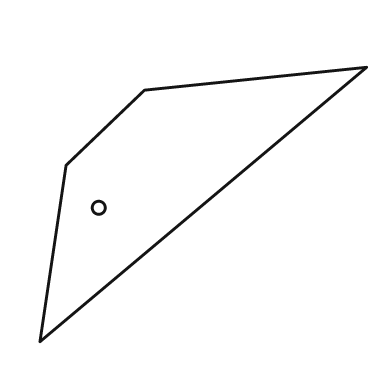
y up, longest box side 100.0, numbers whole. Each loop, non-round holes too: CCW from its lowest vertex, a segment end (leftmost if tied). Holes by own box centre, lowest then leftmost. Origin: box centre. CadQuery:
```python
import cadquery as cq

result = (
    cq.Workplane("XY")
    .moveTo(-50.0, -42.0)
    .lineTo(50.0, 42.0)
    .lineTo(-18.0, 35.0)
    .lineTo(-42.0, 12.0)
    .close()
    .moveTo(-32.0, -1.0)
    .circle(2.0)
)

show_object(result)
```